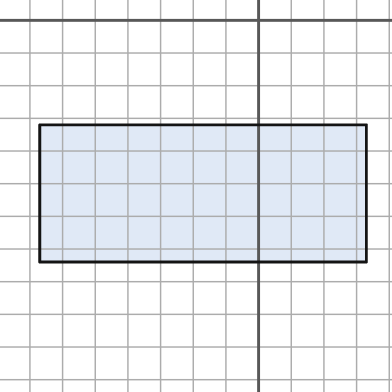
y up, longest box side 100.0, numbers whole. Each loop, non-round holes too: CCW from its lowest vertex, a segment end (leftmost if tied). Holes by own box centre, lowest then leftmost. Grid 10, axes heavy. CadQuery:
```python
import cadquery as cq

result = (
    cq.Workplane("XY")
    .moveTo(-67.0, -74.0)
    .lineTo(33.0, -74.0)
    .lineTo(33.0, -32.0)
    .lineTo(-67.0, -32.0)
    .close()
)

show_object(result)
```